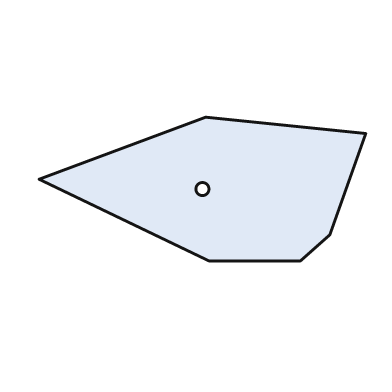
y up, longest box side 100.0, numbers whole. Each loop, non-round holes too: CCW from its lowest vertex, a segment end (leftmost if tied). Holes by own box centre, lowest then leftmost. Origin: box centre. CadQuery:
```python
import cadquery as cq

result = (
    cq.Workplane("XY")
    .moveTo(2.0, -22.0)
    .lineTo(30.0, -22.0)
    .lineTo(39.0, -14.0)
    .lineTo(50.0, 17.0)
    .lineTo(1.0, 22.0)
    .lineTo(-50.0, 3.0)
    .close()
    .moveTo(0.0, 0.0)
    .circle(2.0)
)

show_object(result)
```